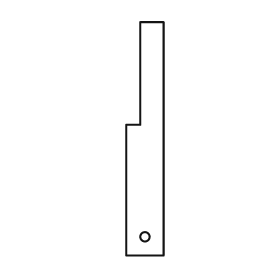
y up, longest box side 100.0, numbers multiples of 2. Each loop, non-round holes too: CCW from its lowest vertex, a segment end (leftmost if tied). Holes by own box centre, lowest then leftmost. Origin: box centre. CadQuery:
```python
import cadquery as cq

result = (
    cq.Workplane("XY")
    .moveTo(-8.0, -50.0)
    .lineTo(8.0, -50.0)
    .lineTo(8.0, 50.0)
    .lineTo(-2.0, 50.0)
    .lineTo(-2.0, 6.0)
    .lineTo(-8.0, 6.0)
    .close()
    .moveTo(0.0, -42.0)
    .circle(2.0)
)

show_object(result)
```